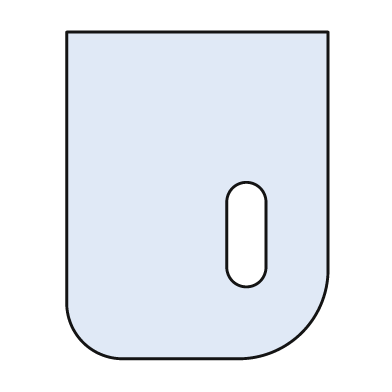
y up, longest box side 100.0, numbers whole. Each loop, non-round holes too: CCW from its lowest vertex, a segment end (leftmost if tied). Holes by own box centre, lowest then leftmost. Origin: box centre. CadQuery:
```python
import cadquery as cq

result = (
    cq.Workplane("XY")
    .moveTo(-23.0, -50.0)
    .lineTo(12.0, -50.0)
    .threePointArc((32.0, -42.0), (40.0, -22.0))
    .lineTo(40.0, 50.0)
    .lineTo(-40.0, 50.0)
    .lineTo(-40.0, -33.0)
    .threePointArc((-35.0, -45.0), (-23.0, -50.0))
    .close()
    .moveTo(9.0, -22.0)
    .threePointArc((15.0, -28.0), (21.0, -22.0))
    .lineTo(21.0, -2.0)
    .threePointArc((15.0, 4.0), (9.0, -2.0))
    .close()
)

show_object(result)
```